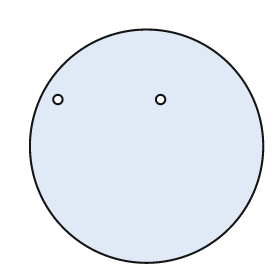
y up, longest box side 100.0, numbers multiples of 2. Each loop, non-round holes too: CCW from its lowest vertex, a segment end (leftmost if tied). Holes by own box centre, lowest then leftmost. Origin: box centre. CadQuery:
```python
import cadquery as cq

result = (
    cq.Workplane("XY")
    .moveTo(0.0, 0.0)
    .circle(50.0)
    .moveTo(-38.0, 20.0)
    .circle(2.0)
    .moveTo(6.0, 20.0)
    .circle(2.0)
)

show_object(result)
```